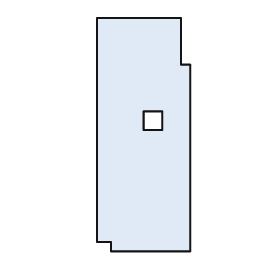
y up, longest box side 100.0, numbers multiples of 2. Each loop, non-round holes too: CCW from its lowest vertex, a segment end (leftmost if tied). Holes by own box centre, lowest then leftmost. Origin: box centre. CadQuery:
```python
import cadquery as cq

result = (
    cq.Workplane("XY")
    .moveTo(-14.0, -50.0)
    .lineTo(20.0, -50.0)
    .lineTo(20.0, 30.0)
    .lineTo(16.0, 30.0)
    .lineTo(16.0, 50.0)
    .lineTo(-20.0, 50.0)
    .lineTo(-20.0, -46.0)
    .lineTo(-14.0, -46.0)
    .close()
    .moveTo(0.0, 2.0)
    .lineTo(8.0, 2.0)
    .lineTo(8.0, 10.0)
    .lineTo(0.0, 10.0)
    .close()
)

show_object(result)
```